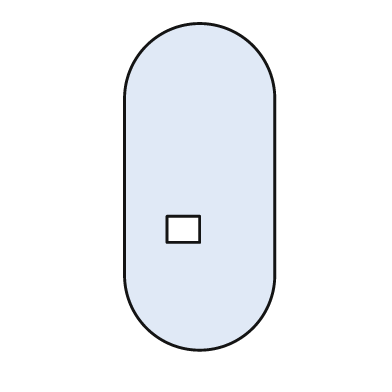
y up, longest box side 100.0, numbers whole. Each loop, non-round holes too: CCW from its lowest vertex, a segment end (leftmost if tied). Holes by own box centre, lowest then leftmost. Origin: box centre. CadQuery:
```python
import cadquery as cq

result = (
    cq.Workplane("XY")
    .moveTo(-23.0, -27.0)
    .threePointArc((0.0, -50.0), (23.0, -27.0))
    .lineTo(23.0, 27.0)
    .threePointArc((0.0, 50.0), (-23.0, 27.0))
    .close()
    .moveTo(-10.0, -17.0)
    .lineTo(0.0, -17.0)
    .lineTo(0.0, -9.0)
    .lineTo(-10.0, -9.0)
    .close()
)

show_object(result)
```